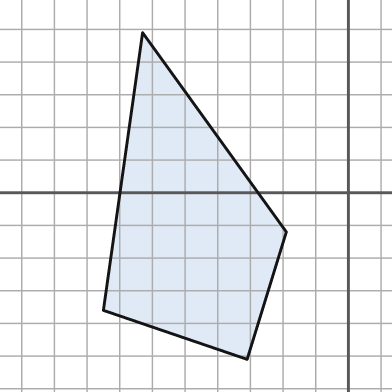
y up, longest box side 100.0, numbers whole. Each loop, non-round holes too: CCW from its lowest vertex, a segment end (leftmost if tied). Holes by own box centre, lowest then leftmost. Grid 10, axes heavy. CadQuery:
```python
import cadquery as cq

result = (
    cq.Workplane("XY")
    .moveTo(-31.0, -51.0)
    .lineTo(-19.0, -12.0)
    .lineTo(-63.0, 49.0)
    .lineTo(-75.0, -36.0)
    .close()
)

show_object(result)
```